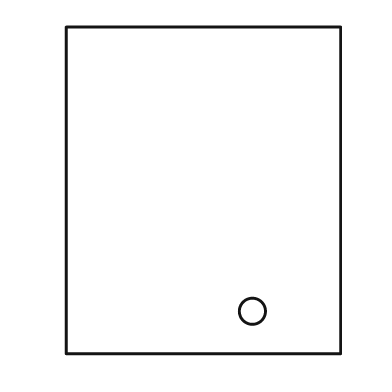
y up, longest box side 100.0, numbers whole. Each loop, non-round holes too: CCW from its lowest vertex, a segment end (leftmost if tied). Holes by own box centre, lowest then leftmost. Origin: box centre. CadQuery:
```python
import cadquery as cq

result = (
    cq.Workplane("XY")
    .moveTo(-42.0, -50.0)
    .lineTo(42.0, -50.0)
    .lineTo(42.0, 50.0)
    .lineTo(-42.0, 50.0)
    .close()
    .moveTo(15.0, -37.0)
    .circle(4.0)
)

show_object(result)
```